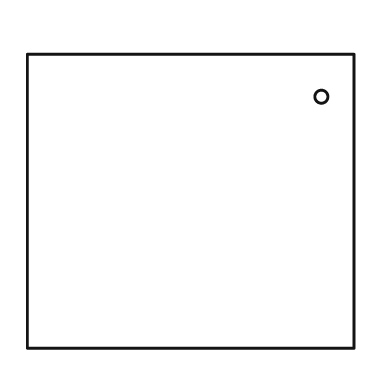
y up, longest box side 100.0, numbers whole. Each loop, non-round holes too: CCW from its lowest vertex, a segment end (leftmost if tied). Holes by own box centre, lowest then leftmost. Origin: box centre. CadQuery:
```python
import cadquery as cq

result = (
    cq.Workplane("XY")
    .moveTo(-50.0, -45.0)
    .lineTo(50.0, -45.0)
    .lineTo(50.0, 45.0)
    .lineTo(-50.0, 45.0)
    .close()
    .moveTo(40.0, 32.0)
    .circle(2.0)
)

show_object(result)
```